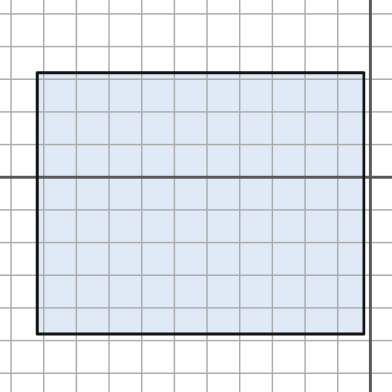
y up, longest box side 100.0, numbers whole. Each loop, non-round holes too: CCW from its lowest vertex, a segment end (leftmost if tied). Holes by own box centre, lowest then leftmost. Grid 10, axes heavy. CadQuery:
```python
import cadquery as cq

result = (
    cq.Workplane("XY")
    .moveTo(-102.0, -48.0)
    .lineTo(-2.0, -48.0)
    .lineTo(-2.0, 32.0)
    .lineTo(-102.0, 32.0)
    .close()
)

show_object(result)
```